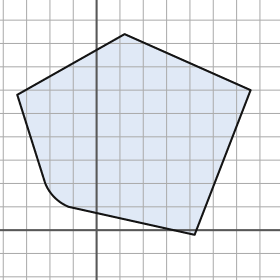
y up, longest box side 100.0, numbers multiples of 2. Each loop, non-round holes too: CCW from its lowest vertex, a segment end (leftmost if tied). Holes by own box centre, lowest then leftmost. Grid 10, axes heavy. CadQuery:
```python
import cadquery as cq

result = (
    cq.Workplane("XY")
    .moveTo(42.0, -2.0)
    .lineTo(66.0, 60.0)
    .lineTo(12.0, 84.0)
    .lineTo(-34.0, 58.0)
    .lineTo(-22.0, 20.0)
    .threePointArc((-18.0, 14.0), (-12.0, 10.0))
    .close()
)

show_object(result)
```